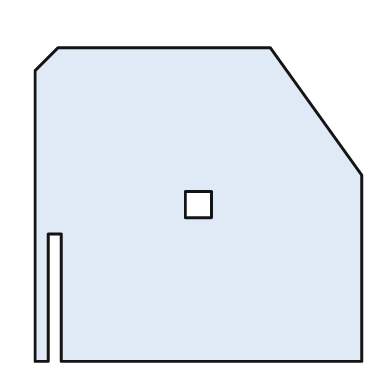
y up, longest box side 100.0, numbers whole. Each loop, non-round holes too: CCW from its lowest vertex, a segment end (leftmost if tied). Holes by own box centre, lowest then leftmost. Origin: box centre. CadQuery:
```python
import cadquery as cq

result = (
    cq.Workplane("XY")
    .moveTo(-50.0, -48.0)
    .lineTo(-46.0, -48.0)
    .lineTo(-46.0, -9.0)
    .lineTo(-42.0, -9.0)
    .lineTo(-42.0, -48.0)
    .lineTo(50.0, -48.0)
    .lineTo(50.0, 9.0)
    .lineTo(22.0, 48.0)
    .lineTo(-43.0, 48.0)
    .lineTo(-50.0, 41.0)
    .close()
    .moveTo(-4.0, -4.0)
    .lineTo(4.0, -4.0)
    .lineTo(4.0, 4.0)
    .lineTo(-4.0, 4.0)
    .close()
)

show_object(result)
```